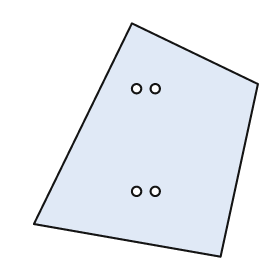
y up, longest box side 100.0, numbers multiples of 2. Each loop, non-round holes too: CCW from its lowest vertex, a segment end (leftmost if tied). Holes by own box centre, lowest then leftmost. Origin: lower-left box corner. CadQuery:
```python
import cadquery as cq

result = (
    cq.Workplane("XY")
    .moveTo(80.0, 0.0)
    .lineTo(96.0, 74.0)
    .lineTo(42.0, 100.0)
    .lineTo(0.0, 14.0)
    .close()
    .moveTo(44.0, 28.0)
    .circle(2.0)
    .moveTo(52.0, 28.0)
    .circle(2.0)
    .moveTo(44.0, 72.0)
    .circle(2.0)
    .moveTo(52.0, 72.0)
    .circle(2.0)
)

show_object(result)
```